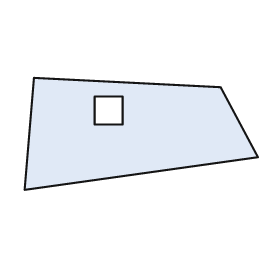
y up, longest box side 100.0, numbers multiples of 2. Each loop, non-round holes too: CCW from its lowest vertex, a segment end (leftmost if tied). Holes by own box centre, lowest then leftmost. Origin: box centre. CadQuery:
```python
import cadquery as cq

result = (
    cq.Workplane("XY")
    .moveTo(-50.0, -24.0)
    .lineTo(50.0, -10.0)
    .lineTo(34.0, 20.0)
    .lineTo(-46.0, 24.0)
    .close()
    .moveTo(-20.0, 4.0)
    .lineTo(-8.0, 4.0)
    .lineTo(-8.0, 16.0)
    .lineTo(-20.0, 16.0)
    .close()
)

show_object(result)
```